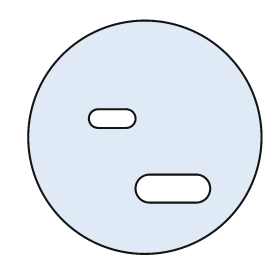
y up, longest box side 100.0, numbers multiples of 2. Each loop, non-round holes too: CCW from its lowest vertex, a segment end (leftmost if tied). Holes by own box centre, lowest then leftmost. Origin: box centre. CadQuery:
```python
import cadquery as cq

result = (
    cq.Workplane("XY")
    .moveTo(0.0, 0.0)
    .circle(50.0)
    .moveTo(2.0, -28.0)
    .lineTo(22.0, -28.0)
    .threePointArc((28.0, -22.0), (22.0, -16.0))
    .lineTo(2.0, -16.0)
    .threePointArc((-4.0, -22.0), (2.0, -28.0))
    .close()
    .moveTo(-20.0, 4.0)
    .lineTo(-8.0, 4.0)
    .threePointArc((-4.0, 8.0), (-8.0, 12.0))
    .lineTo(-20.0, 12.0)
    .threePointArc((-24.0, 8.0), (-20.0, 4.0))
    .close()
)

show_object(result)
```